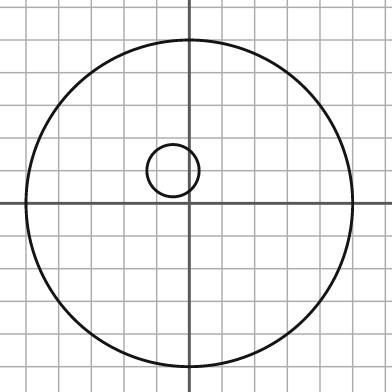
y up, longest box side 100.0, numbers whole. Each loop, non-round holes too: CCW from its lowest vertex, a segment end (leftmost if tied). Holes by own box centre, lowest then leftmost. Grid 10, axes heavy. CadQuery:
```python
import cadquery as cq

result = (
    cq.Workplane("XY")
    .moveTo(0.0, 0.0)
    .circle(50.0)
    .moveTo(-5.0, 10.0)
    .circle(8.0)
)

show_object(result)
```